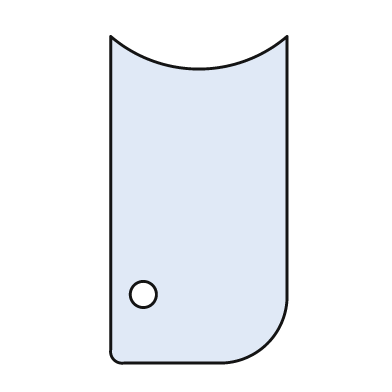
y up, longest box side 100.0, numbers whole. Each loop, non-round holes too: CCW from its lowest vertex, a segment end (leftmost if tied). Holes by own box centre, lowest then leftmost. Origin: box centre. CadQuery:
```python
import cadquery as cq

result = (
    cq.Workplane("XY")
    .moveTo(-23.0, -50.0)
    .lineTo(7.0, -50.0)
    .threePointArc((21.0, -44.0), (27.0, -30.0))
    .lineTo(27.0, 50.0)
    .threePointArc((0.0, 40.0), (-27.0, 50.0))
    .lineTo(-27.0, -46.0)
    .threePointArc((-26.0, -49.0), (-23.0, -50.0))
    .close()
    .moveTo(-17.0, -29.0)
    .circle(4.0)
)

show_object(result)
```